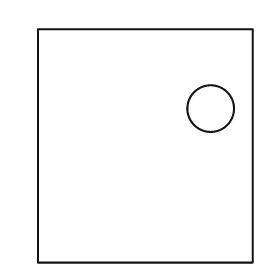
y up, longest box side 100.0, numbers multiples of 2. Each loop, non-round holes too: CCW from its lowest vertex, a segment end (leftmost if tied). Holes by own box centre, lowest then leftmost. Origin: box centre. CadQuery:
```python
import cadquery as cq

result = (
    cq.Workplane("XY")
    .moveTo(-46.0, -50.0)
    .lineTo(46.0, -50.0)
    .lineTo(46.0, 50.0)
    .lineTo(-46.0, 50.0)
    .close()
    .moveTo(28.0, 16.0)
    .circle(10.0)
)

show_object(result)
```